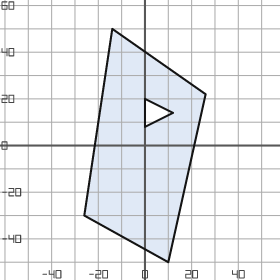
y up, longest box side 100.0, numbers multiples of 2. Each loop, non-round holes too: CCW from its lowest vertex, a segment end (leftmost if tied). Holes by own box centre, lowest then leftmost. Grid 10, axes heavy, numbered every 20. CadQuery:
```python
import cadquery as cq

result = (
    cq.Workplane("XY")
    .moveTo(10.0, -50.0)
    .lineTo(26.0, 22.0)
    .lineTo(-14.0, 50.0)
    .lineTo(-26.0, -30.0)
    .close()
    .moveTo(0.0, 8.0)
    .lineTo(12.0, 14.0)
    .lineTo(0.0, 20.0)
    .close()
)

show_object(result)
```